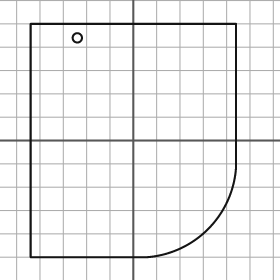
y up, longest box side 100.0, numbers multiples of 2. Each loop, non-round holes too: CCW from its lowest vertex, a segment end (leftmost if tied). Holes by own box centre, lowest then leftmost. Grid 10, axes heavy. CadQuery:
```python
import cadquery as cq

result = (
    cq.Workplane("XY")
    .moveTo(-44.0, -50.0)
    .lineTo(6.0, -50.0)
    .threePointArc((32.0, -38.0), (44.0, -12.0))
    .lineTo(44.0, 50.0)
    .lineTo(-44.0, 50.0)
    .close()
    .moveTo(-24.0, 44.0)
    .circle(2.0)
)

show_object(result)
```